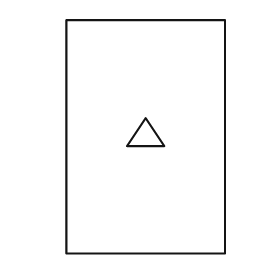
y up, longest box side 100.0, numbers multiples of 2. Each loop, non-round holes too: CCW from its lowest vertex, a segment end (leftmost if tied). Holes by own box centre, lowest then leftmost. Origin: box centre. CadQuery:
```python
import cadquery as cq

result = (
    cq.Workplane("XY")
    .moveTo(-34.0, -50.0)
    .lineTo(34.0, -50.0)
    .lineTo(34.0, 50.0)
    .lineTo(-34.0, 50.0)
    .close()
    .moveTo(-8.0, -4.0)
    .lineTo(8.0, -4.0)
    .lineTo(0.0, 8.0)
    .close()
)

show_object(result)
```